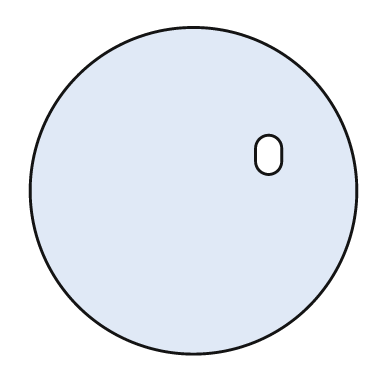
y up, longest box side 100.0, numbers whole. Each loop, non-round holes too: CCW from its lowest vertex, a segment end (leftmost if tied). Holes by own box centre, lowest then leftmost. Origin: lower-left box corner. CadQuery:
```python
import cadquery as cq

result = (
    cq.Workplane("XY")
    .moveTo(50.0, 50.0)
    .circle(50.0)
    .moveTo(69.0, 59.0)
    .threePointArc((73.0, 55.0), (77.0, 59.0))
    .lineTo(77.0, 63.0)
    .threePointArc((73.0, 67.0), (69.0, 63.0))
    .close()
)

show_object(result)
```